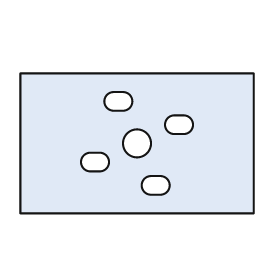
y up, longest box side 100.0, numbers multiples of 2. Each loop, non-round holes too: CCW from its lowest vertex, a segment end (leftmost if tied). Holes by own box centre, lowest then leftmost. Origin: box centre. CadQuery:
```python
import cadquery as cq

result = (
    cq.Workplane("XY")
    .moveTo(-50.0, -30.0)
    .lineTo(50.0, -30.0)
    .lineTo(50.0, 30.0)
    .lineTo(-50.0, 30.0)
    .close()
    .moveTo(6.0, -22.0)
    .lineTo(10.0, -22.0)
    .threePointArc((14.0, -18.0), (10.0, -14.0))
    .lineTo(6.0, -14.0)
    .threePointArc((2.0, -18.0), (6.0, -22.0))
    .close()
    .moveTo(-20.0, -12.0)
    .lineTo(-16.0, -12.0)
    .threePointArc((-12.0, -8.0), (-16.0, -4.0))
    .lineTo(-20.0, -4.0)
    .threePointArc((-24.0, -8.0), (-20.0, -12.0))
    .close()
    .moveTo(0.0, 0.0)
    .circle(6.0)
    .moveTo(16.0, 4.0)
    .lineTo(20.0, 4.0)
    .threePointArc((24.0, 8.0), (20.0, 12.0))
    .lineTo(16.0, 12.0)
    .threePointArc((12.0, 8.0), (16.0, 4.0))
    .close()
    .moveTo(-10.0, 14.0)
    .lineTo(-6.0, 14.0)
    .threePointArc((-2.0, 18.0), (-6.0, 22.0))
    .lineTo(-10.0, 22.0)
    .threePointArc((-14.0, 18.0), (-10.0, 14.0))
    .close()
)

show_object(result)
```